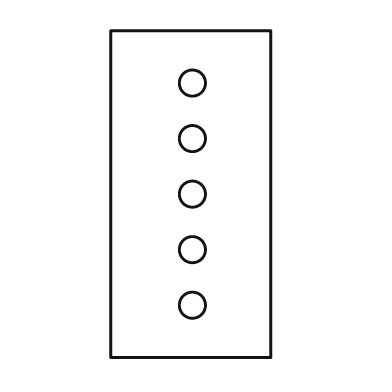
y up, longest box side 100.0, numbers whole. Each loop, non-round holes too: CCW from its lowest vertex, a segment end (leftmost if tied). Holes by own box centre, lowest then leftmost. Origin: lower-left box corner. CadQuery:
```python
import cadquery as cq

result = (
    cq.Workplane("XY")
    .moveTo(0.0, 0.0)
    .lineTo(49.0, 0.0)
    .lineTo(49.0, 100.0)
    .lineTo(0.0, 100.0)
    .close()
    .moveTo(25.0, 16.0)
    .circle(4.0)
    .moveTo(25.0, 33.0)
    .circle(4.0)
    .moveTo(25.0, 50.0)
    .circle(4.0)
    .moveTo(25.0, 67.0)
    .circle(4.0)
    .moveTo(25.0, 84.0)
    .circle(4.0)
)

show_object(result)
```